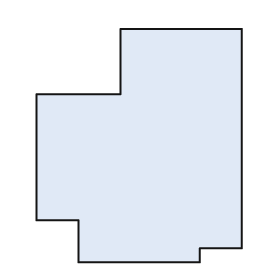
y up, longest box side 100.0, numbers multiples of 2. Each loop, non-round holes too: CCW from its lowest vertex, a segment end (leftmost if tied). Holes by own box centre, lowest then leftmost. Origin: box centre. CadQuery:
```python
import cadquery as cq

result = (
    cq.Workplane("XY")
    .moveTo(-26.0, -50.0)
    .lineTo(26.0, -50.0)
    .lineTo(26.0, -44.0)
    .lineTo(44.0, -44.0)
    .lineTo(44.0, 50.0)
    .lineTo(-8.0, 50.0)
    .lineTo(-8.0, 22.0)
    .lineTo(-44.0, 22.0)
    .lineTo(-44.0, -32.0)
    .lineTo(-26.0, -32.0)
    .close()
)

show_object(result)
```